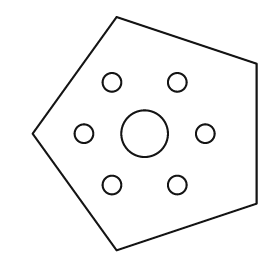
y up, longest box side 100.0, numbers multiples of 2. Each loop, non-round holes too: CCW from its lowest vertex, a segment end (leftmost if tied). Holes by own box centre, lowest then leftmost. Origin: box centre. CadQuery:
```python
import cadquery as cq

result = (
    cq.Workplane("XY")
    .moveTo(-12.0, -50.0)
    .lineTo(48.0, -30.0)
    .lineTo(48.0, 30.0)
    .lineTo(-12.0, 50.0)
    .lineTo(-48.0, 0.0)
    .close()
    .moveTo(-14.0, -22.0)
    .circle(4.0)
    .moveTo(14.0, -22.0)
    .circle(4.0)
    .moveTo(-26.0, 0.0)
    .circle(4.0)
    .moveTo(0.0, 0.0)
    .circle(10.0)
    .moveTo(26.0, 0.0)
    .circle(4.0)
    .moveTo(-14.0, 22.0)
    .circle(4.0)
    .moveTo(14.0, 22.0)
    .circle(4.0)
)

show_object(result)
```